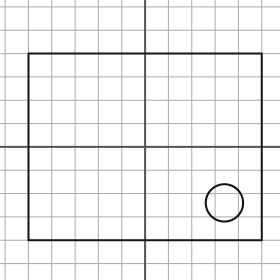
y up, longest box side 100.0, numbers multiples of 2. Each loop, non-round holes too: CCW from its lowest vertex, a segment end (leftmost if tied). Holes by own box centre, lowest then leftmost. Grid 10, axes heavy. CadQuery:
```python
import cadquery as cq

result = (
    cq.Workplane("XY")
    .moveTo(-50.0, -40.0)
    .lineTo(50.0, -40.0)
    .lineTo(50.0, 40.0)
    .lineTo(-50.0, 40.0)
    .close()
    .moveTo(34.0, -24.0)
    .circle(8.0)
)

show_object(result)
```